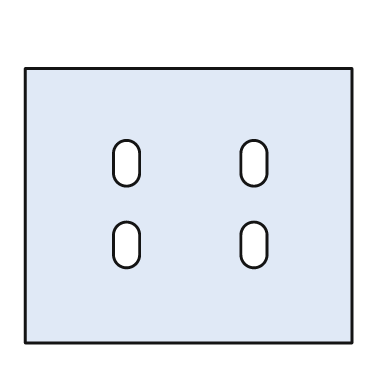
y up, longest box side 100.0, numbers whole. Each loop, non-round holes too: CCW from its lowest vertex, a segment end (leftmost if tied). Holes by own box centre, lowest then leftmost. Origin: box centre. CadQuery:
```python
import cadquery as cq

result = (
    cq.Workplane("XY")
    .moveTo(-50.0, -42.0)
    .lineTo(50.0, -42.0)
    .lineTo(50.0, 42.0)
    .lineTo(-50.0, 42.0)
    .close()
    .moveTo(-23.0, -15.0)
    .threePointArc((-19.0, -19.0), (-15.0, -15.0))
    .lineTo(-15.0, -9.0)
    .threePointArc((-19.0, -5.0), (-23.0, -9.0))
    .close()
    .moveTo(16.0, -15.0)
    .threePointArc((20.0, -19.0), (24.0, -15.0))
    .lineTo(24.0, -9.0)
    .threePointArc((20.0, -5.0), (16.0, -9.0))
    .close()
    .moveTo(-23.0, 10.0)
    .threePointArc((-19.0, 6.0), (-15.0, 10.0))
    .lineTo(-15.0, 16.0)
    .threePointArc((-19.0, 20.0), (-23.0, 16.0))
    .close()
    .moveTo(16.0, 10.0)
    .threePointArc((20.0, 6.0), (24.0, 10.0))
    .lineTo(24.0, 16.0)
    .threePointArc((20.0, 20.0), (16.0, 16.0))
    .close()
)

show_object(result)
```